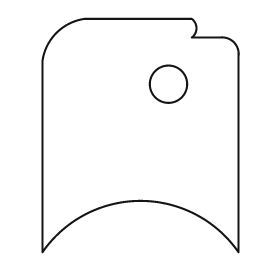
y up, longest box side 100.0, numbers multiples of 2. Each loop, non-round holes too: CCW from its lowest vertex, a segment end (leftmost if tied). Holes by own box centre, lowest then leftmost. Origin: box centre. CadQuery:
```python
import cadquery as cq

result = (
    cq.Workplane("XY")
    .moveTo(-42.0, -50.0)
    .threePointArc((0.0, -28.0), (42.0, -50.0))
    .lineTo(42.0, 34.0)
    .threePointArc((40.0, 40.0), (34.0, 42.0))
    .lineTo(22.0, 42.0)
    .threePointArc((24.0, 46.0), (22.0, 50.0))
    .lineTo(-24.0, 50.0)
    .threePointArc((-36.0, 44.0), (-42.0, 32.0))
    .close()
    .moveTo(12.0, 22.0)
    .circle(8.0)
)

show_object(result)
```